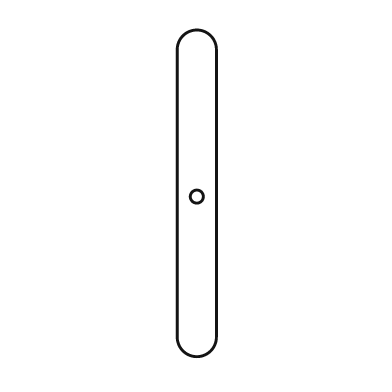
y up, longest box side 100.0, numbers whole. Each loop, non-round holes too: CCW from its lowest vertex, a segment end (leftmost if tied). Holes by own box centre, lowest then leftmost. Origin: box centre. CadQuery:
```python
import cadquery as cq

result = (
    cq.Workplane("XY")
    .moveTo(-6.0, -44.0)
    .threePointArc((0.0, -50.0), (6.0, -44.0))
    .lineTo(6.0, 44.0)
    .threePointArc((0.0, 50.0), (-6.0, 44.0))
    .close()
    .moveTo(0.0, -1.0)
    .circle(2.0)
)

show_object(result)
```